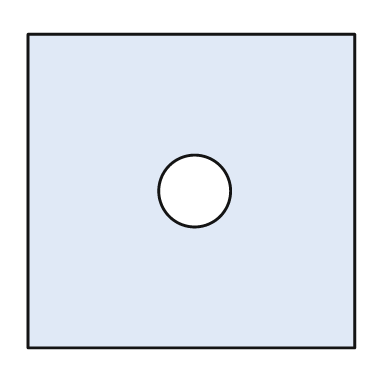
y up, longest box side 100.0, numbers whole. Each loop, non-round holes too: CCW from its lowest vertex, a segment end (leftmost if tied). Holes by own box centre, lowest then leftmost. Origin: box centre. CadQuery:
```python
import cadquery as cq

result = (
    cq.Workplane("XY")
    .moveTo(-50.0, -48.0)
    .lineTo(50.0, -48.0)
    .lineTo(50.0, 48.0)
    .lineTo(-50.0, 48.0)
    .close()
    .moveTo(1.0, 0.0)
    .circle(11.0)
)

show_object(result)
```